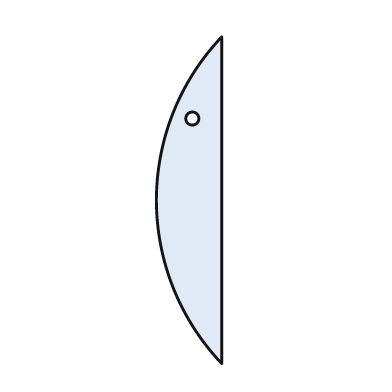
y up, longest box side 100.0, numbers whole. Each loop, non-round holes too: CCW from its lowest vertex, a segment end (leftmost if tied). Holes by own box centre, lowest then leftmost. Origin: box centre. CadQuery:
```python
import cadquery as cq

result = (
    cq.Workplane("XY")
    .moveTo(10.0, -50.0)
    .lineTo(10.0, 50.0)
    .threePointArc((-10.0, 0.0), (10.0, -50.0))
    .close()
    .moveTo(1.0, 25.0)
    .circle(2.0)
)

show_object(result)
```